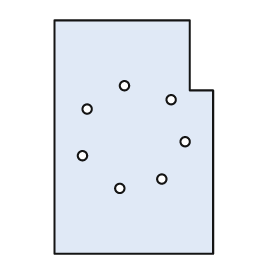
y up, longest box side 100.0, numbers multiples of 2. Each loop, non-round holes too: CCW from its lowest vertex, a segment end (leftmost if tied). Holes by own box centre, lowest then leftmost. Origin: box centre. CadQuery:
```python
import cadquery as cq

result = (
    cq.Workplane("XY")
    .moveTo(-34.0, -50.0)
    .lineTo(34.0, -50.0)
    .lineTo(34.0, 20.0)
    .lineTo(24.0, 20.0)
    .lineTo(24.0, 50.0)
    .lineTo(-34.0, 50.0)
    .close()
    .moveTo(-6.0, -22.0)
    .circle(2.0)
    .moveTo(12.0, -18.0)
    .circle(2.0)
    .moveTo(-22.0, -8.0)
    .circle(2.0)
    .moveTo(22.0, -2.0)
    .circle(2.0)
    .moveTo(-20.0, 12.0)
    .circle(2.0)
    .moveTo(16.0, 16.0)
    .circle(2.0)
    .moveTo(-4.0, 22.0)
    .circle(2.0)
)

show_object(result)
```